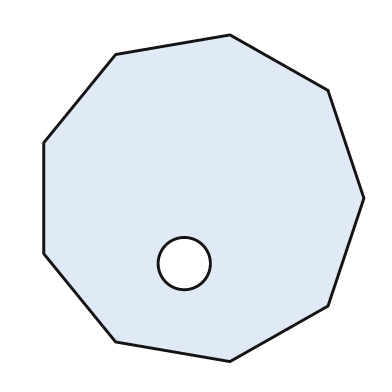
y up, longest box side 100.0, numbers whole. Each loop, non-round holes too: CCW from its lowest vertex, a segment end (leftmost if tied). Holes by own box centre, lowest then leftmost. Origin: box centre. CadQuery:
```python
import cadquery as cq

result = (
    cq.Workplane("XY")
    .moveTo(8.0, -50.0)
    .lineTo(38.0, -33.0)
    .lineTo(49.0, 0.0)
    .lineTo(38.0, 33.0)
    .lineTo(8.0, 50.0)
    .lineTo(-27.0, 44.0)
    .lineTo(-49.0, 17.0)
    .lineTo(-49.0, -17.0)
    .lineTo(-27.0, -44.0)
    .close()
    .moveTo(-6.0, -20.0)
    .circle(8.0)
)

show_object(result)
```